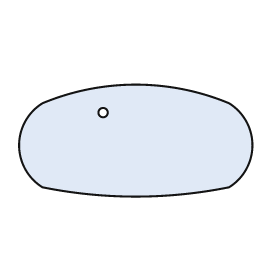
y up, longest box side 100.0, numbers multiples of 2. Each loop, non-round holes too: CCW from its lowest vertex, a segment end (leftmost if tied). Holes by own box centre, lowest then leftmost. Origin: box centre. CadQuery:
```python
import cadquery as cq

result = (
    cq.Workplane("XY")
    .moveTo(-40.0, -20.0)
    .threePointArc((0.0, -24.0), (40.0, -20.0))
    .threePointArc((50.0, -2.0), (40.0, 16.0))
    .threePointArc((0.0, 24.0), (-40.0, 16.0))
    .threePointArc((-50.0, -2.0), (-40.0, -20.0))
    .close()
    .moveTo(-14.0, 12.0)
    .circle(2.0)
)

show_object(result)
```